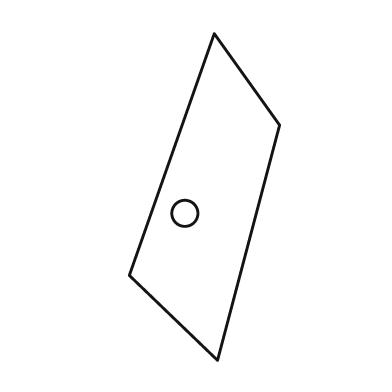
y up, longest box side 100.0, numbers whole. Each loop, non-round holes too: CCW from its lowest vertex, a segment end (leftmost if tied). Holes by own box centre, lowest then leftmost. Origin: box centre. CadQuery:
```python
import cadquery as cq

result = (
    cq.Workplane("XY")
    .moveTo(4.0, -50.0)
    .lineTo(23.0, 22.0)
    .lineTo(3.0, 50.0)
    .lineTo(-23.0, -24.0)
    .close()
    .moveTo(-6.0, -5.0)
    .circle(4.0)
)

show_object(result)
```